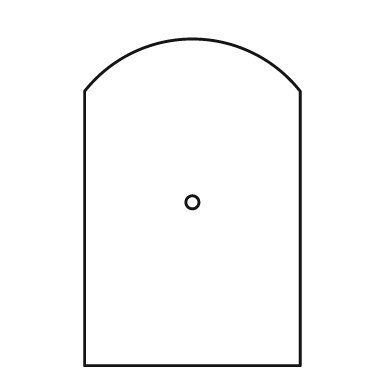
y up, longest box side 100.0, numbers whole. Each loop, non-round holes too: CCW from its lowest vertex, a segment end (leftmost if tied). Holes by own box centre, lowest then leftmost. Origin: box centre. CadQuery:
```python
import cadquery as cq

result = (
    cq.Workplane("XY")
    .moveTo(-33.0, -50.0)
    .lineTo(33.0, -50.0)
    .lineTo(33.0, 34.0)
    .threePointArc((0.0, 50.0), (-33.0, 34.0))
    .close()
    .moveTo(0.0, 0.0)
    .circle(2.0)
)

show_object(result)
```